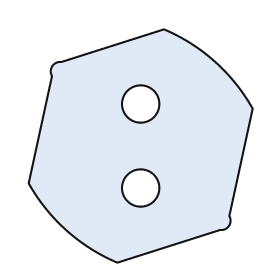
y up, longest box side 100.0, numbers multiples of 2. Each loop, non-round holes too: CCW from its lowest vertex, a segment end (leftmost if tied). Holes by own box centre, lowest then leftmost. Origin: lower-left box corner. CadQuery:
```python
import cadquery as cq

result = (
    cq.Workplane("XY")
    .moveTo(38.0, 0.0)
    .lineTo(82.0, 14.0)
    .threePointArc((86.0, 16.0), (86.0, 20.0))
    .lineTo(96.0, 66.0)
    .threePointArc((80.0, 86.0), (58.0, 100.0))
    .lineTo(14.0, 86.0)
    .threePointArc((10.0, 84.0), (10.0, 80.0))
    .lineTo(0.0, 34.0)
    .threePointArc((16.0, 14.0), (38.0, 0.0))
    .close()
    .moveTo(48.0, 32.0)
    .circle(8.0)
    .moveTo(48.0, 68.0)
    .circle(8.0)
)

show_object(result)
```